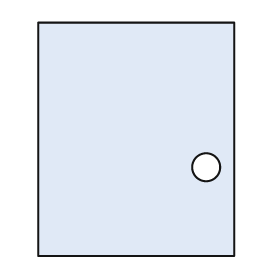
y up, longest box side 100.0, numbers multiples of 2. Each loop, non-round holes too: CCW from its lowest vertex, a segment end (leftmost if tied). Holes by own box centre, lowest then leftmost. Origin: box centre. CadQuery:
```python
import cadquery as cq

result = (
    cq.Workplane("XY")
    .moveTo(-42.0, -50.0)
    .lineTo(42.0, -50.0)
    .lineTo(42.0, 50.0)
    .lineTo(-42.0, 50.0)
    .close()
    .moveTo(30.0, -12.0)
    .circle(6.0)
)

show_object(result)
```